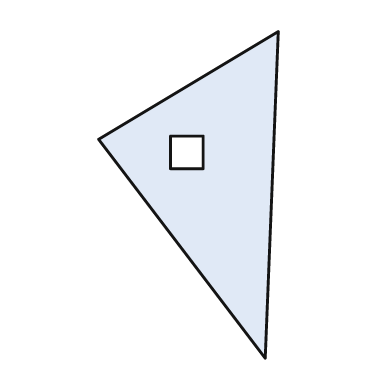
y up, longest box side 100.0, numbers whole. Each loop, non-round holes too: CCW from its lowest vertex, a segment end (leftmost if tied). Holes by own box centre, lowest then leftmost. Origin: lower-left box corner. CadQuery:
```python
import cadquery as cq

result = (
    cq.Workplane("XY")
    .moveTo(51.0, 0.0)
    .lineTo(55.0, 100.0)
    .lineTo(0.0, 67.0)
    .close()
    .moveTo(22.0, 58.0)
    .lineTo(32.0, 58.0)
    .lineTo(32.0, 68.0)
    .lineTo(22.0, 68.0)
    .close()
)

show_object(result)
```